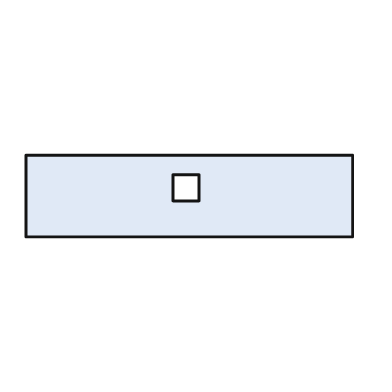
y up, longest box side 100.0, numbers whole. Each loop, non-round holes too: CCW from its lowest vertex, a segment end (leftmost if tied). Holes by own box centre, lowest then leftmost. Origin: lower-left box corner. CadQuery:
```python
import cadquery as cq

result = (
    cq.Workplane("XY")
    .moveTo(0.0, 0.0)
    .lineTo(100.0, 0.0)
    .lineTo(100.0, 25.0)
    .lineTo(0.0, 25.0)
    .close()
    .moveTo(45.0, 11.0)
    .lineTo(53.0, 11.0)
    .lineTo(53.0, 19.0)
    .lineTo(45.0, 19.0)
    .close()
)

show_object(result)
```